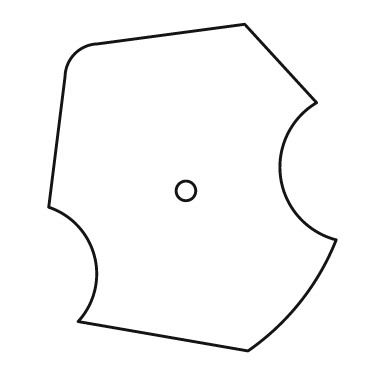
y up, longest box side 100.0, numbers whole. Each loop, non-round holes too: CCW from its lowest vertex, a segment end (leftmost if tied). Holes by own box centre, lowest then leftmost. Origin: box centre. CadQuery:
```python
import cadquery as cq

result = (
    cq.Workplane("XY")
    .moveTo(17.0, -50.0)
    .threePointArc((33.0, -35.0), (44.0, -16.0))
    .threePointArc((27.0, 3.0), (38.0, 26.0))
    .lineTo(16.0, 50.0)
    .lineTo(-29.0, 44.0)
    .threePointArc((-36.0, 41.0), (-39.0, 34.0))
    .lineTo(-44.0, -6.0)
    .threePointArc((-30.0, -21.0), (-35.0, -41.0))
    .close()
    .moveTo(-2.0, -1.0)
    .circle(3.0)
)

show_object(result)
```